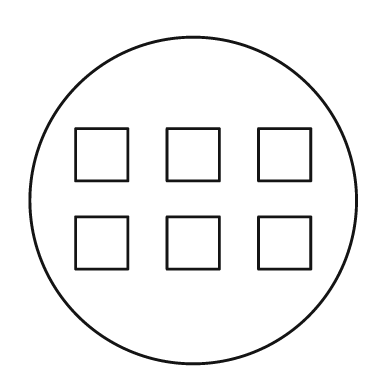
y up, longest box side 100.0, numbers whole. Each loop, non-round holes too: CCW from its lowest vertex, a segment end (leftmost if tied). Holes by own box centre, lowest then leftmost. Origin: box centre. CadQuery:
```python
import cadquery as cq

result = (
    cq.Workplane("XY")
    .moveTo(0.0, 0.0)
    .circle(50.0)
    .moveTo(-36.0, -21.0)
    .lineTo(-20.0, -21.0)
    .lineTo(-20.0, -5.0)
    .lineTo(-36.0, -5.0)
    .close()
    .moveTo(-8.0, -21.0)
    .lineTo(8.0, -21.0)
    .lineTo(8.0, -5.0)
    .lineTo(-8.0, -5.0)
    .close()
    .moveTo(20.0, -21.0)
    .lineTo(36.0, -21.0)
    .lineTo(36.0, -5.0)
    .lineTo(20.0, -5.0)
    .close()
    .moveTo(-36.0, 6.0)
    .lineTo(-20.0, 6.0)
    .lineTo(-20.0, 22.0)
    .lineTo(-36.0, 22.0)
    .close()
    .moveTo(-8.0, 6.0)
    .lineTo(8.0, 6.0)
    .lineTo(8.0, 22.0)
    .lineTo(-8.0, 22.0)
    .close()
    .moveTo(20.0, 6.0)
    .lineTo(36.0, 6.0)
    .lineTo(36.0, 22.0)
    .lineTo(20.0, 22.0)
    .close()
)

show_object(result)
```